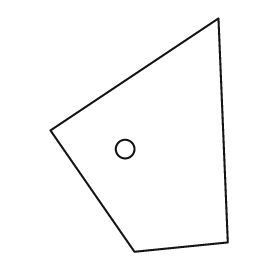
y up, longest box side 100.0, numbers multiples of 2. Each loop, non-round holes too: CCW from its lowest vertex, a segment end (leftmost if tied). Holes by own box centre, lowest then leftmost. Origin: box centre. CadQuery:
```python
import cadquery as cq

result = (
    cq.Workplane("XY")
    .moveTo(-2.0, -50.0)
    .lineTo(38.0, -46.0)
    .lineTo(34.0, 50.0)
    .lineTo(-38.0, 2.0)
    .close()
    .moveTo(-6.0, -6.0)
    .circle(4.0)
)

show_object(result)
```